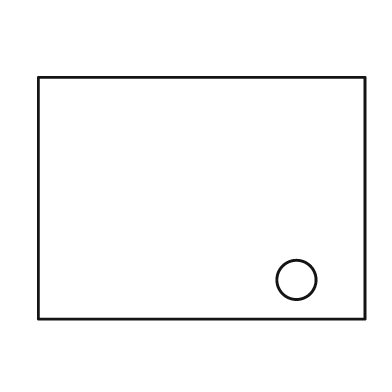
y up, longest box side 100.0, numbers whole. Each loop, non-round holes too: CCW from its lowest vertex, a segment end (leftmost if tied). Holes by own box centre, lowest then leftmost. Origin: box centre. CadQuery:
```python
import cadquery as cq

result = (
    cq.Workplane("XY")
    .moveTo(-50.0, -37.0)
    .lineTo(50.0, -37.0)
    .lineTo(50.0, 37.0)
    .lineTo(-50.0, 37.0)
    .close()
    .moveTo(29.0, -25.0)
    .circle(6.0)
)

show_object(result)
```